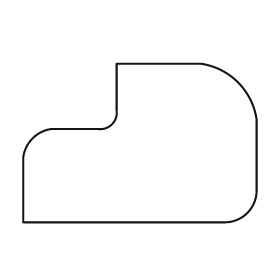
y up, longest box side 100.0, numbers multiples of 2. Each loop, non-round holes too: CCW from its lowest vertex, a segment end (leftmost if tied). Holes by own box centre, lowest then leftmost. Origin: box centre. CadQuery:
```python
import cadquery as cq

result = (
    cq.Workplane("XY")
    .moveTo(-50.0, -34.0)
    .lineTo(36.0, -34.0)
    .threePointArc((46.0, -30.0), (50.0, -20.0))
    .lineTo(50.0, 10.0)
    .threePointArc((42.0, 26.0), (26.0, 34.0))
    .lineTo(-10.0, 34.0)
    .lineTo(-10.0, 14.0)
    .threePointArc((-12.0, 8.0), (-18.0, 6.0))
    .lineTo(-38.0, 6.0)
    .threePointArc((-46.0, 2.0), (-50.0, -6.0))
    .close()
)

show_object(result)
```